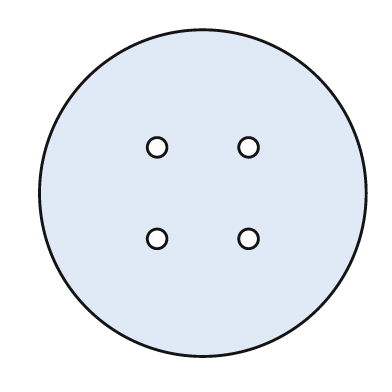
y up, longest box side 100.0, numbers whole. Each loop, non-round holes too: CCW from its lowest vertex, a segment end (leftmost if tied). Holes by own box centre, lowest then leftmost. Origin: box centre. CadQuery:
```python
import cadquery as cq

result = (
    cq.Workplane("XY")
    .moveTo(0.0, 0.0)
    .circle(50.0)
    .moveTo(-14.0, -14.0)
    .circle(3.0)
    .moveTo(14.0, -14.0)
    .circle(3.0)
    .moveTo(-14.0, 14.0)
    .circle(3.0)
    .moveTo(14.0, 14.0)
    .circle(3.0)
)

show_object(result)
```